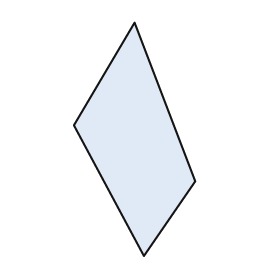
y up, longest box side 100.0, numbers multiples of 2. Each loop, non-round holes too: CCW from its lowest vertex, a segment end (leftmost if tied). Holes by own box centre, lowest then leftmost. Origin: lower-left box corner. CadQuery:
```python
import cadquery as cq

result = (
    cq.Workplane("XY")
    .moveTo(30.0, 0.0)
    .lineTo(52.0, 32.0)
    .lineTo(26.0, 100.0)
    .lineTo(0.0, 56.0)
    .close()
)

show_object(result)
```